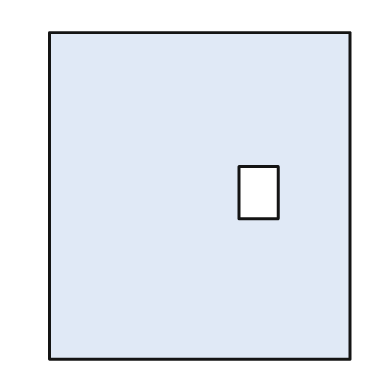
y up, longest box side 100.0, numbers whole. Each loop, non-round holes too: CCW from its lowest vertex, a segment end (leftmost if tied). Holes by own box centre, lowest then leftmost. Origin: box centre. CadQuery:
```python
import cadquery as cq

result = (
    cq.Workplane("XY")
    .moveTo(-46.0, -50.0)
    .lineTo(46.0, -50.0)
    .lineTo(46.0, 50.0)
    .lineTo(-46.0, 50.0)
    .close()
    .moveTo(12.0, -7.0)
    .lineTo(24.0, -7.0)
    .lineTo(24.0, 9.0)
    .lineTo(12.0, 9.0)
    .close()
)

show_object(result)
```